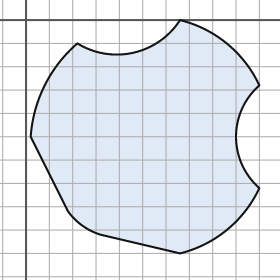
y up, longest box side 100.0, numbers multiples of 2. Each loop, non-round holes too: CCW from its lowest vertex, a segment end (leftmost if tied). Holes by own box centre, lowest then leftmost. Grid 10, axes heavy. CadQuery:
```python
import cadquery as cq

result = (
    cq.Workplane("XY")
    .moveTo(66.0, -100.0)
    .threePointArc((86.0, -90.0), (100.0, -72.0))
    .threePointArc((90.0, -50.0), (100.0, -28.0))
    .threePointArc((86.0, -10.0), (66.0, 0.0))
    .threePointArc((46.0, -14.0), (22.0, -10.0))
    .threePointArc((8.0, -28.0), (2.0, -50.0))
    .lineTo(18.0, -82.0)
    .threePointArc((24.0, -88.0), (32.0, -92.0))
    .close()
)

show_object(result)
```